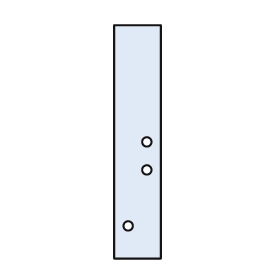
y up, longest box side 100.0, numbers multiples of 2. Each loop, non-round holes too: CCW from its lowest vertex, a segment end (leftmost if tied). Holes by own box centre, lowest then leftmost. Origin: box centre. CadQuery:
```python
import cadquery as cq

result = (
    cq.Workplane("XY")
    .moveTo(-10.0, -50.0)
    .lineTo(10.0, -50.0)
    .lineTo(10.0, 50.0)
    .lineTo(-10.0, 50.0)
    .close()
    .moveTo(-4.0, -36.0)
    .circle(2.0)
    .moveTo(4.0, -12.0)
    .circle(2.0)
    .moveTo(4.0, 0.0)
    .circle(2.0)
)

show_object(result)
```